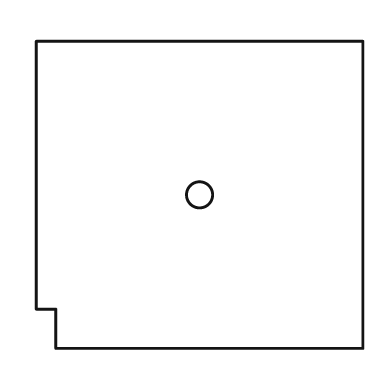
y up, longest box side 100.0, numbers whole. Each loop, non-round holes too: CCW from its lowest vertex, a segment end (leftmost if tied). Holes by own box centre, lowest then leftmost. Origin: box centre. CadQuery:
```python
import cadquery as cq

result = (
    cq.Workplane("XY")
    .moveTo(-44.0, -47.0)
    .lineTo(50.0, -47.0)
    .lineTo(50.0, 47.0)
    .lineTo(-50.0, 47.0)
    .lineTo(-50.0, -35.0)
    .lineTo(-44.0, -35.0)
    .close()
    .moveTo(0.0, 0.0)
    .circle(4.0)
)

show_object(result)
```